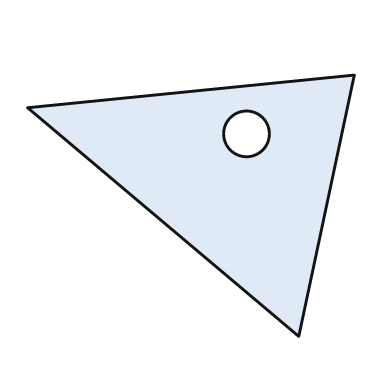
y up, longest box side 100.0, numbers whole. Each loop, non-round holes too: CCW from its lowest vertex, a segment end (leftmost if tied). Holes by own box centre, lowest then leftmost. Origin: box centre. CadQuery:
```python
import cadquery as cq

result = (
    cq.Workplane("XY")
    .moveTo(33.0, -40.0)
    .lineTo(50.0, 40.0)
    .lineTo(-50.0, 30.0)
    .close()
    .moveTo(17.0, 22.0)
    .circle(7.0)
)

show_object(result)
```